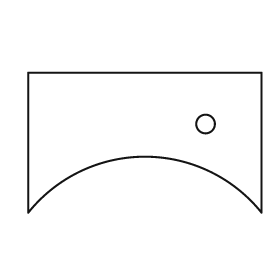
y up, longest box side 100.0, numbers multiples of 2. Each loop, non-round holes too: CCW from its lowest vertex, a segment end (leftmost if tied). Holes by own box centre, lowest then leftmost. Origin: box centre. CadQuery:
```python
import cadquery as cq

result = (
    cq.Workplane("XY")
    .moveTo(-50.0, -30.0)
    .threePointArc((0.0, -6.0), (50.0, -30.0))
    .lineTo(50.0, 30.0)
    .lineTo(-50.0, 30.0)
    .close()
    .moveTo(26.0, 8.0)
    .circle(4.0)
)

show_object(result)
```